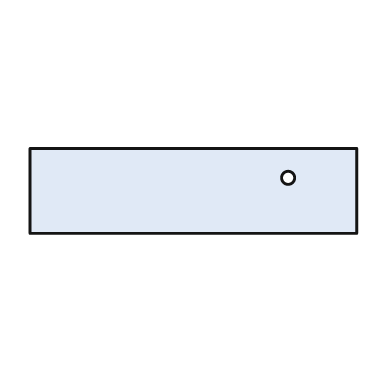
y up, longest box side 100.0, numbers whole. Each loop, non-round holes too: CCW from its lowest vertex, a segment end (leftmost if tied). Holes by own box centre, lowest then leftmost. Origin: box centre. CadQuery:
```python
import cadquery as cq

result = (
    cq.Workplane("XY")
    .moveTo(-50.0, -13.0)
    .lineTo(50.0, -13.0)
    .lineTo(50.0, 13.0)
    .lineTo(-50.0, 13.0)
    .close()
    .moveTo(29.0, 4.0)
    .circle(2.0)
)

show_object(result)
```